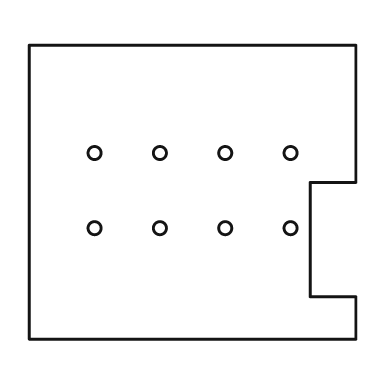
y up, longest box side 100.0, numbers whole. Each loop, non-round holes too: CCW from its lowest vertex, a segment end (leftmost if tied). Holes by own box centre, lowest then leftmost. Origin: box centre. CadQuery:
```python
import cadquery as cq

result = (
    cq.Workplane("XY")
    .moveTo(-50.0, -45.0)
    .lineTo(50.0, -45.0)
    .lineTo(50.0, -32.0)
    .lineTo(36.0, -32.0)
    .lineTo(36.0, 3.0)
    .lineTo(50.0, 3.0)
    .lineTo(50.0, 45.0)
    .lineTo(-50.0, 45.0)
    .close()
    .moveTo(-30.0, -11.0)
    .circle(2.0)
    .moveTo(-10.0, -11.0)
    .circle(2.0)
    .moveTo(10.0, -11.0)
    .circle(2.0)
    .moveTo(30.0, -11.0)
    .circle(2.0)
    .moveTo(-30.0, 12.0)
    .circle(2.0)
    .moveTo(-10.0, 12.0)
    .circle(2.0)
    .moveTo(10.0, 12.0)
    .circle(2.0)
    .moveTo(30.0, 12.0)
    .circle(2.0)
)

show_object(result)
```